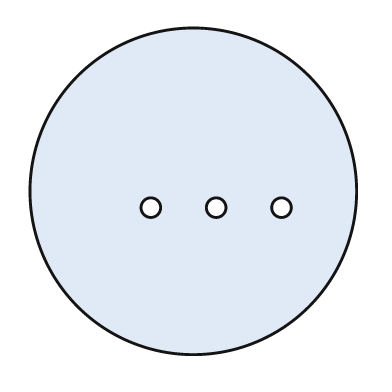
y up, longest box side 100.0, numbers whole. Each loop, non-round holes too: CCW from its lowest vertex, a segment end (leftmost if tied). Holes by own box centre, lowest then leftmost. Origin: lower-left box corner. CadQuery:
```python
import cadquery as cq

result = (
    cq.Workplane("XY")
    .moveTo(50.0, 50.0)
    .circle(50.0)
    .moveTo(37.0, 45.0)
    .circle(3.0)
    .moveTo(57.0, 45.0)
    .circle(3.0)
    .moveTo(77.0, 45.0)
    .circle(3.0)
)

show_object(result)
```